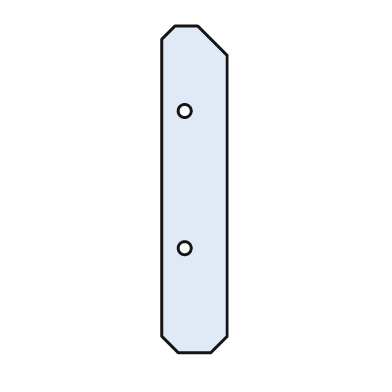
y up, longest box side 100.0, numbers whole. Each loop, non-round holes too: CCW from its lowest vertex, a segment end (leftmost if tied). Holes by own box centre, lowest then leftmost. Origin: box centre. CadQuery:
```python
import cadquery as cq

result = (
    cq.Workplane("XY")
    .moveTo(-5.0, -50.0)
    .lineTo(5.0, -50.0)
    .lineTo(10.0, -45.0)
    .lineTo(10.0, 41.0)
    .lineTo(1.0, 50.0)
    .lineTo(-6.0, 50.0)
    .lineTo(-10.0, 46.0)
    .lineTo(-10.0, -45.0)
    .close()
    .moveTo(-3.0, -18.0)
    .circle(2.0)
    .moveTo(-3.0, 24.0)
    .circle(2.0)
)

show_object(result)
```